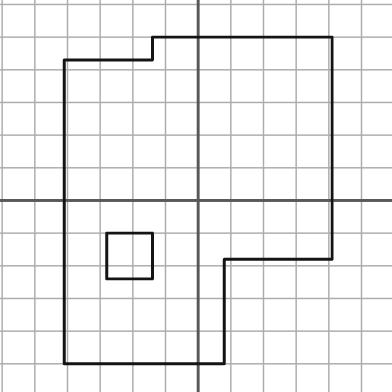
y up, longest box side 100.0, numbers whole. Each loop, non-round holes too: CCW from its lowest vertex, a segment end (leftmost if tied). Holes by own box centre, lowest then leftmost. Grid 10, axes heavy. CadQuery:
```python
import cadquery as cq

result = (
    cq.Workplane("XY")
    .moveTo(-41.0, -50.0)
    .lineTo(8.0, -50.0)
    .lineTo(8.0, -18.0)
    .lineTo(41.0, -18.0)
    .lineTo(41.0, 50.0)
    .lineTo(-14.0, 50.0)
    .lineTo(-14.0, 43.0)
    .lineTo(-41.0, 43.0)
    .close()
    .moveTo(-28.0, -24.0)
    .lineTo(-14.0, -24.0)
    .lineTo(-14.0, -10.0)
    .lineTo(-28.0, -10.0)
    .close()
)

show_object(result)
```